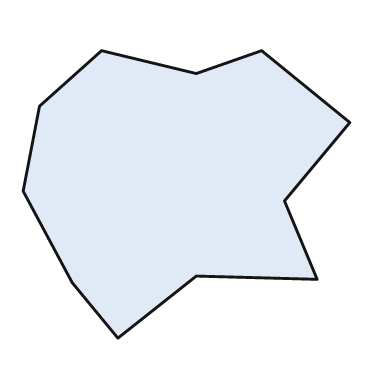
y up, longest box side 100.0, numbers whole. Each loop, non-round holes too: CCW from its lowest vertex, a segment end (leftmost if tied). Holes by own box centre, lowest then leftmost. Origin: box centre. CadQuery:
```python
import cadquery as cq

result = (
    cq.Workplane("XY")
    .moveTo(-21.0, -44.0)
    .lineTo(3.0, -25.0)
    .lineTo(40.0, -26.0)
    .lineTo(30.0, -2.0)
    .lineTo(50.0, 22.0)
    .lineTo(23.0, 44.0)
    .lineTo(3.0, 37.0)
    .lineTo(-26.0, 44.0)
    .lineTo(-45.0, 27.0)
    .lineTo(-50.0, 1.0)
    .lineTo(-35.0, -27.0)
    .close()
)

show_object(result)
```